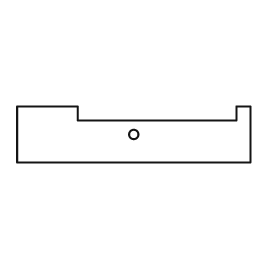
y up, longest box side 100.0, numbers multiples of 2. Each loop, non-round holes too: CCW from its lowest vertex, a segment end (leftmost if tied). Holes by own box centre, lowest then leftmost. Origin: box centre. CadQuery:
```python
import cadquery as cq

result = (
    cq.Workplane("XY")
    .moveTo(-50.0, -12.0)
    .lineTo(50.0, -12.0)
    .lineTo(50.0, 12.0)
    .lineTo(44.0, 12.0)
    .lineTo(44.0, 6.0)
    .lineTo(-24.0, 6.0)
    .lineTo(-24.0, 12.0)
    .lineTo(-50.0, 12.0)
    .close()
    .moveTo(0.0, 0.0)
    .circle(2.0)
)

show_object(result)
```